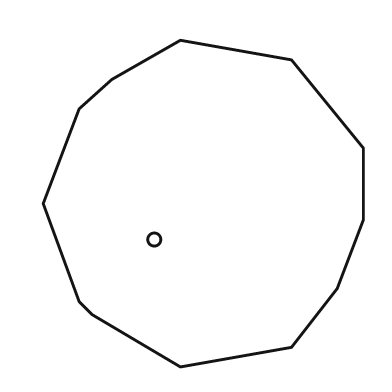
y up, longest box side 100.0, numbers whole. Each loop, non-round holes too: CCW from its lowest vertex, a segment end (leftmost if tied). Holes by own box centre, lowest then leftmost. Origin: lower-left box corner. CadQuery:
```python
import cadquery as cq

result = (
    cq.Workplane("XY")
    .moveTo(42.0, 0.0)
    .lineTo(76.0, 6.0)
    .lineTo(90.0, 24.0)
    .lineTo(98.0, 45.0)
    .lineTo(98.0, 67.0)
    .lineTo(76.0, 94.0)
    .lineTo(42.0, 100.0)
    .lineTo(21.0, 88.0)
    .lineTo(11.0, 79.0)
    .lineTo(0.0, 50.0)
    .lineTo(11.0, 20.0)
    .lineTo(15.0, 16.0)
    .close()
    .moveTo(34.0, 39.0)
    .circle(2.0)
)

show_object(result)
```